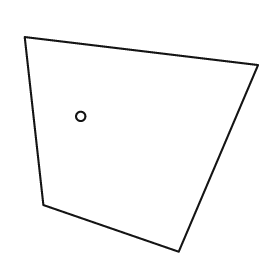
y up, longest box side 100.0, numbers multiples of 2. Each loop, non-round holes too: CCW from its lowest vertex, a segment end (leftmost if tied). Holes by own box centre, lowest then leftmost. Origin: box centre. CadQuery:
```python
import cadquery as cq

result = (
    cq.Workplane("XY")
    .moveTo(16.0, -46.0)
    .lineTo(50.0, 34.0)
    .lineTo(-50.0, 46.0)
    .lineTo(-42.0, -26.0)
    .close()
    .moveTo(-26.0, 12.0)
    .circle(2.0)
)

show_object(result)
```